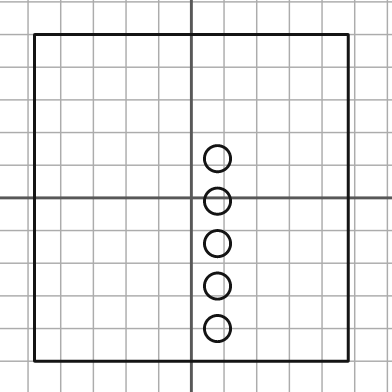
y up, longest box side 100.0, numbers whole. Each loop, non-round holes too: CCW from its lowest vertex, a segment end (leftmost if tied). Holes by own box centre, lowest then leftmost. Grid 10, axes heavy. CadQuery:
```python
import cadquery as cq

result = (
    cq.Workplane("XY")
    .moveTo(-48.0, -50.0)
    .lineTo(48.0, -50.0)
    .lineTo(48.0, 50.0)
    .lineTo(-48.0, 50.0)
    .close()
    .moveTo(8.0, -40.0)
    .circle(4.0)
    .moveTo(8.0, -27.0)
    .circle(4.0)
    .moveTo(8.0, -14.0)
    .circle(4.0)
    .moveTo(8.0, -1.0)
    .circle(4.0)
    .moveTo(8.0, 12.0)
    .circle(4.0)
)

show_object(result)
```